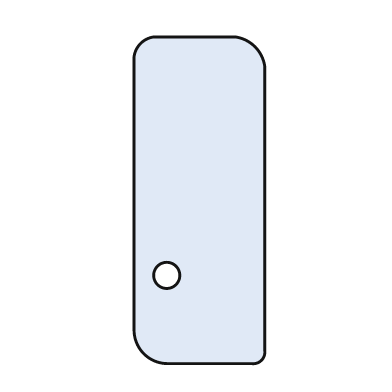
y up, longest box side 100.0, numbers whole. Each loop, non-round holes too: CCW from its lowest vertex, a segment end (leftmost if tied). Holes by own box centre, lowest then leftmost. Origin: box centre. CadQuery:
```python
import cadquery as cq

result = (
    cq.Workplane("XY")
    .moveTo(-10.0, -50.0)
    .lineTo(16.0, -50.0)
    .threePointArc((19.0, -49.0), (20.0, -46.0))
    .lineTo(20.0, 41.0)
    .threePointArc((17.0, 47.0), (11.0, 50.0))
    .lineTo(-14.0, 50.0)
    .threePointArc((-18.0, 48.0), (-20.0, 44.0))
    .lineTo(-20.0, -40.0)
    .threePointArc((-17.0, -47.0), (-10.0, -50.0))
    .close()
    .moveTo(-10.0, -23.0)
    .circle(4.0)
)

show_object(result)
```